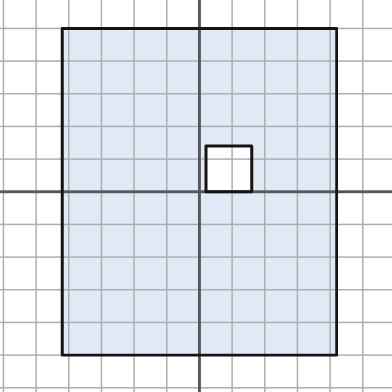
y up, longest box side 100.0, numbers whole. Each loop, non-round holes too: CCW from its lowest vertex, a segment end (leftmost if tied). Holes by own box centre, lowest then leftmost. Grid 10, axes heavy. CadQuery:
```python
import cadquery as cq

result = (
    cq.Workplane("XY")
    .moveTo(-42.0, -50.0)
    .lineTo(42.0, -50.0)
    .lineTo(42.0, 50.0)
    .lineTo(-42.0, 50.0)
    .close()
    .moveTo(2.0, 0.0)
    .lineTo(16.0, 0.0)
    .lineTo(16.0, 14.0)
    .lineTo(2.0, 14.0)
    .close()
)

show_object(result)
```